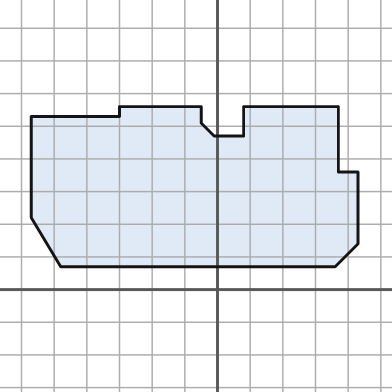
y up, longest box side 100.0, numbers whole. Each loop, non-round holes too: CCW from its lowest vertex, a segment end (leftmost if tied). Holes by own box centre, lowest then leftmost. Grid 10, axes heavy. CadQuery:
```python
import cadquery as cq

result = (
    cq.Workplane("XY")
    .moveTo(-48.0, 7.0)
    .lineTo(36.0, 7.0)
    .lineTo(43.0, 14.0)
    .lineTo(43.0, 36.0)
    .lineTo(37.0, 36.0)
    .lineTo(37.0, 56.0)
    .lineTo(8.0, 56.0)
    .lineTo(8.0, 47.0)
    .lineTo(-1.0, 47.0)
    .lineTo(-5.0, 51.0)
    .lineTo(-5.0, 56.0)
    .lineTo(-30.0, 56.0)
    .lineTo(-30.0, 53.0)
    .lineTo(-57.0, 53.0)
    .lineTo(-57.0, 22.0)
    .close()
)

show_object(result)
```